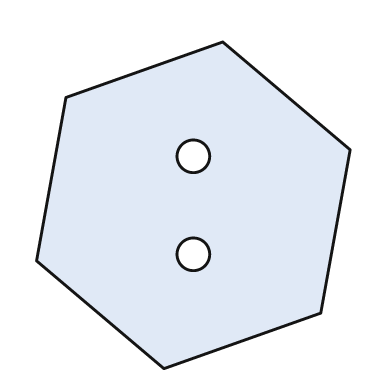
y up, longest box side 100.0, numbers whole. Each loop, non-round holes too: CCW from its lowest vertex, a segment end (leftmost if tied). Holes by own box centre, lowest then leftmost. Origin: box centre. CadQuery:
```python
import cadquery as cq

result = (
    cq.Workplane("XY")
    .moveTo(-9.0, -50.0)
    .lineTo(39.0, -33.0)
    .lineTo(48.0, 17.0)
    .lineTo(9.0, 50.0)
    .lineTo(-39.0, 33.0)
    .lineTo(-48.0, -17.0)
    .close()
    .moveTo(0.0, -15.0)
    .circle(5.0)
    .moveTo(0.0, 15.0)
    .circle(5.0)
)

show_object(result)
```